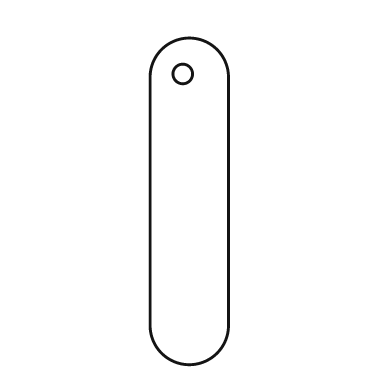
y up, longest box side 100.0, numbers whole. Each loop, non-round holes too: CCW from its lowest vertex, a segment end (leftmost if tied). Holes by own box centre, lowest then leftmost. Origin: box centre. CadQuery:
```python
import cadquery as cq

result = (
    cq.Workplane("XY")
    .moveTo(-12.0, -38.0)
    .threePointArc((0.0, -50.0), (12.0, -38.0))
    .lineTo(12.0, 38.0)
    .threePointArc((0.0, 50.0), (-12.0, 38.0))
    .close()
    .moveTo(-2.0, 39.0)
    .circle(3.0)
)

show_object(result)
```